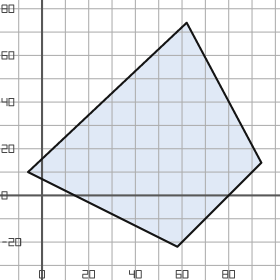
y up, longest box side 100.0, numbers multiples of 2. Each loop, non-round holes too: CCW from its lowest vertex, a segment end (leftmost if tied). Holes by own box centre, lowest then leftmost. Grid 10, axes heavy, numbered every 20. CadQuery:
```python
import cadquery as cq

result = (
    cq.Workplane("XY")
    .moveTo(58.0, -22.0)
    .lineTo(94.0, 14.0)
    .lineTo(62.0, 74.0)
    .lineTo(-6.0, 10.0)
    .close()
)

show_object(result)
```